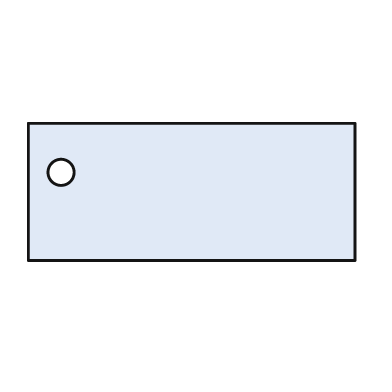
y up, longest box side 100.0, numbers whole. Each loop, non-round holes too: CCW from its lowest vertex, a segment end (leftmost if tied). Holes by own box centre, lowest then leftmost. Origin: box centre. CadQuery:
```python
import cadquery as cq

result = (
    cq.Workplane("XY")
    .moveTo(-50.0, -21.0)
    .lineTo(50.0, -21.0)
    .lineTo(50.0, 21.0)
    .lineTo(-50.0, 21.0)
    .close()
    .moveTo(-40.0, 6.0)
    .circle(4.0)
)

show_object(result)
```